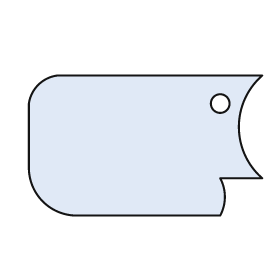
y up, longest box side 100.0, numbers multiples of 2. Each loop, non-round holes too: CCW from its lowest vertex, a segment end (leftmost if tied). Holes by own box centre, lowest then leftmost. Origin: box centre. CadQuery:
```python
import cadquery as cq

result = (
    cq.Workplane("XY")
    .moveTo(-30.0, -30.0)
    .lineTo(32.0, -30.0)
    .threePointArc((34.0, -22.0), (32.0, -14.0))
    .lineTo(50.0, -14.0)
    .threePointArc((40.0, 8.0), (50.0, 30.0))
    .lineTo(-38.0, 30.0)
    .threePointArc((-46.0, 26.0), (-50.0, 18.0))
    .lineTo(-50.0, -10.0)
    .threePointArc((-44.0, -24.0), (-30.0, -30.0))
    .close()
    .moveTo(32.0, 18.0)
    .circle(4.0)
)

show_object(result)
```